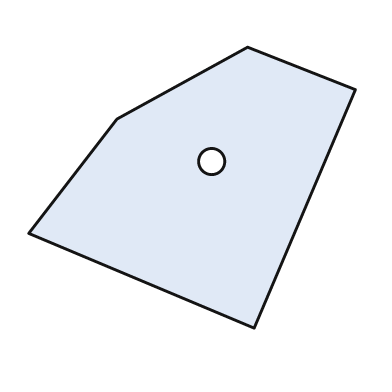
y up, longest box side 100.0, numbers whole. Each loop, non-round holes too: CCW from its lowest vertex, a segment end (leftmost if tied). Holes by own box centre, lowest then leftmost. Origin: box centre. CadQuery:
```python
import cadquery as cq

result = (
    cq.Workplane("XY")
    .moveTo(19.0, -43.0)
    .lineTo(50.0, 30.0)
    .lineTo(17.0, 43.0)
    .lineTo(-23.0, 21.0)
    .lineTo(-50.0, -14.0)
    .close()
    .moveTo(6.0, 8.0)
    .circle(4.0)
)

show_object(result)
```